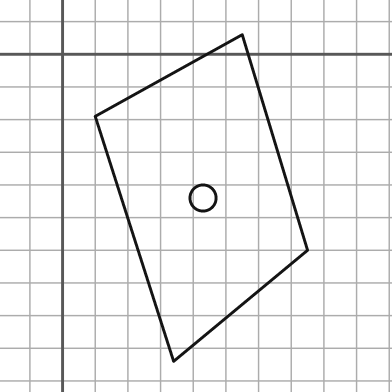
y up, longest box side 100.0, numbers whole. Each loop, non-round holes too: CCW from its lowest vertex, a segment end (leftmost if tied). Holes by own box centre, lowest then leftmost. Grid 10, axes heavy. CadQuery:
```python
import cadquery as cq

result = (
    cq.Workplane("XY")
    .moveTo(34.0, -94.0)
    .lineTo(75.0, -60.0)
    .lineTo(55.0, 6.0)
    .lineTo(10.0, -19.0)
    .close()
    .moveTo(43.0, -44.0)
    .circle(4.0)
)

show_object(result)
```